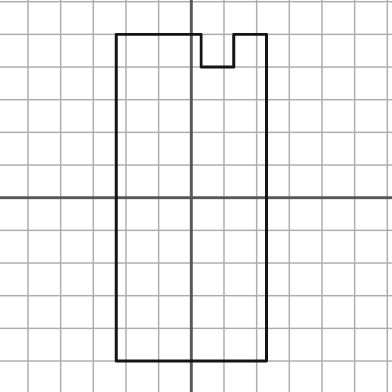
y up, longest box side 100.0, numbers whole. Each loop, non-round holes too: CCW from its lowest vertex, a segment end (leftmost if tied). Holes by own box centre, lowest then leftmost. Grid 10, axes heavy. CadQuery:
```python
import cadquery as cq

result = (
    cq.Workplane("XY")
    .moveTo(-23.0, -50.0)
    .lineTo(23.0, -50.0)
    .lineTo(23.0, 50.0)
    .lineTo(13.0, 50.0)
    .lineTo(13.0, 40.0)
    .lineTo(3.0, 40.0)
    .lineTo(3.0, 50.0)
    .lineTo(-23.0, 50.0)
    .close()
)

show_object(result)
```